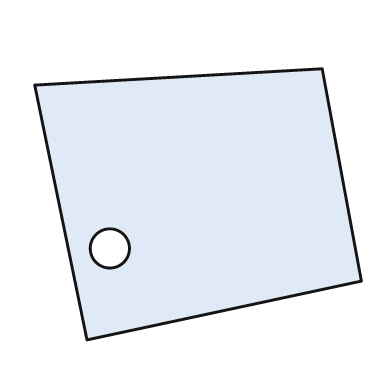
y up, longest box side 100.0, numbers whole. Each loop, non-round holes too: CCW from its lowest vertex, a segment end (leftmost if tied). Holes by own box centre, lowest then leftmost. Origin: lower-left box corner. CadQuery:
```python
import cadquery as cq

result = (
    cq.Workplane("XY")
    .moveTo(16.0, 0.0)
    .lineTo(100.0, 18.0)
    .lineTo(88.0, 83.0)
    .lineTo(0.0, 78.0)
    .close()
    .moveTo(23.0, 28.0)
    .circle(6.0)
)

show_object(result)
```